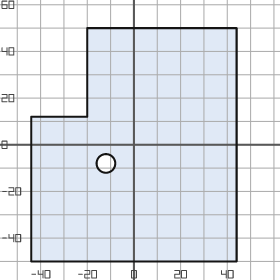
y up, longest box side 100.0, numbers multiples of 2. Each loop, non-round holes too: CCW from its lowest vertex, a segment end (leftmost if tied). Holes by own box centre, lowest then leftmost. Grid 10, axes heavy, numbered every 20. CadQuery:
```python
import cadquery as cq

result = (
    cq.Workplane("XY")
    .moveTo(-44.0, -50.0)
    .lineTo(44.0, -50.0)
    .lineTo(44.0, 50.0)
    .lineTo(-20.0, 50.0)
    .lineTo(-20.0, 12.0)
    .lineTo(-44.0, 12.0)
    .close()
    .moveTo(-12.0, -8.0)
    .circle(4.0)
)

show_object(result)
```